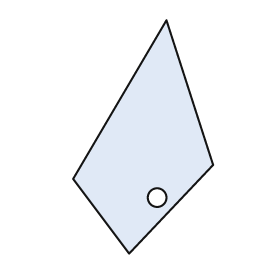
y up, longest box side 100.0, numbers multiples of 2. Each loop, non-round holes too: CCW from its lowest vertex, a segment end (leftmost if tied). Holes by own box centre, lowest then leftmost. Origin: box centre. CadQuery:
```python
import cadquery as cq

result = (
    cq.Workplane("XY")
    .moveTo(-6.0, -50.0)
    .lineTo(30.0, -12.0)
    .lineTo(10.0, 50.0)
    .lineTo(-30.0, -18.0)
    .close()
    .moveTo(6.0, -26.0)
    .circle(4.0)
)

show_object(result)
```